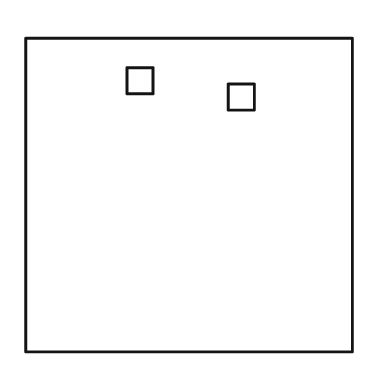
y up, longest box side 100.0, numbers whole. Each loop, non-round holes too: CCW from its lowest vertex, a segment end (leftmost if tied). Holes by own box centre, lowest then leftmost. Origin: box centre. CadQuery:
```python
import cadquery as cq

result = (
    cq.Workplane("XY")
    .moveTo(-50.0, -48.0)
    .lineTo(50.0, -48.0)
    .lineTo(50.0, 48.0)
    .lineTo(-50.0, 48.0)
    .close()
    .moveTo(12.0, 26.0)
    .lineTo(20.0, 26.0)
    .lineTo(20.0, 34.0)
    .lineTo(12.0, 34.0)
    .close()
    .moveTo(-19.0, 31.0)
    .lineTo(-11.0, 31.0)
    .lineTo(-11.0, 39.0)
    .lineTo(-19.0, 39.0)
    .close()
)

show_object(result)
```